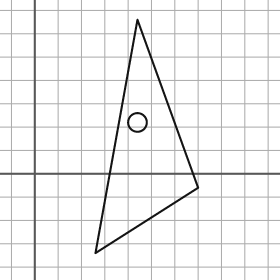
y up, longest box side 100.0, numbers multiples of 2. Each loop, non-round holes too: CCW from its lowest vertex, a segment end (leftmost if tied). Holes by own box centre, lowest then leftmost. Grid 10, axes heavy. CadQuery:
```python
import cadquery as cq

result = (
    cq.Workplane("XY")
    .moveTo(26.0, -34.0)
    .lineTo(70.0, -6.0)
    .lineTo(44.0, 66.0)
    .close()
    .moveTo(44.0, 22.0)
    .circle(4.0)
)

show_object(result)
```